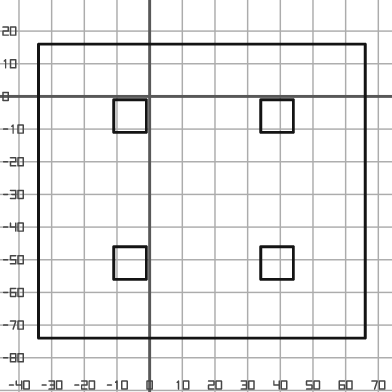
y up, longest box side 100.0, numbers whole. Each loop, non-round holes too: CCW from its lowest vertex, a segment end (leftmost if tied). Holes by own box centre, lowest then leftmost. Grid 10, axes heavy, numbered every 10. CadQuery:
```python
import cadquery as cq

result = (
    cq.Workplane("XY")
    .moveTo(-34.0, -74.0)
    .lineTo(66.0, -74.0)
    .lineTo(66.0, 16.0)
    .lineTo(-34.0, 16.0)
    .close()
    .moveTo(-11.0, -56.0)
    .lineTo(-1.0, -56.0)
    .lineTo(-1.0, -46.0)
    .lineTo(-11.0, -46.0)
    .close()
    .moveTo(34.0, -56.0)
    .lineTo(44.0, -56.0)
    .lineTo(44.0, -46.0)
    .lineTo(34.0, -46.0)
    .close()
    .moveTo(-11.0, -11.0)
    .lineTo(-1.0, -11.0)
    .lineTo(-1.0, -1.0)
    .lineTo(-11.0, -1.0)
    .close()
    .moveTo(34.0, -11.0)
    .lineTo(44.0, -11.0)
    .lineTo(44.0, -1.0)
    .lineTo(34.0, -1.0)
    .close()
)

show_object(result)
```